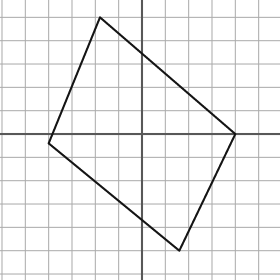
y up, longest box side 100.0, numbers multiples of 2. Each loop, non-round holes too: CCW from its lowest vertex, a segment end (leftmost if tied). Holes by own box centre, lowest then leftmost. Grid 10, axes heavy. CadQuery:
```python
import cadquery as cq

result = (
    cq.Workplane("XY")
    .moveTo(16.0, -50.0)
    .lineTo(40.0, 0.0)
    .lineTo(-18.0, 50.0)
    .lineTo(-40.0, -4.0)
    .close()
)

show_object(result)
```